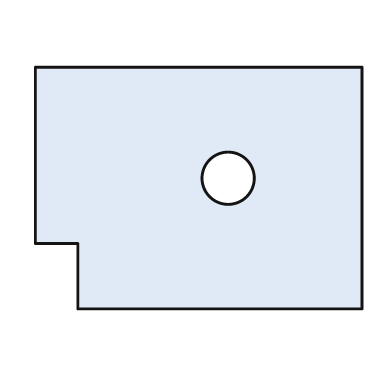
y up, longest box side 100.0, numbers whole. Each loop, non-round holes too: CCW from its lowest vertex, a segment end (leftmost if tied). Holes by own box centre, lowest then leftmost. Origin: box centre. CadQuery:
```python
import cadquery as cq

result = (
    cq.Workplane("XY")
    .moveTo(-37.0, -37.0)
    .lineTo(50.0, -37.0)
    .lineTo(50.0, 37.0)
    .lineTo(-50.0, 37.0)
    .lineTo(-50.0, -17.0)
    .lineTo(-37.0, -17.0)
    .close()
    .moveTo(9.0, 3.0)
    .circle(8.0)
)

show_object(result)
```